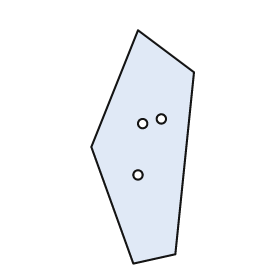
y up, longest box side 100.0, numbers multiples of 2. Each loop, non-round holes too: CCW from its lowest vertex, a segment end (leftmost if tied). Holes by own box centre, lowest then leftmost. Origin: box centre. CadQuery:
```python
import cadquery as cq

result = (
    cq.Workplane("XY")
    .moveTo(-4.0, -50.0)
    .lineTo(14.0, -46.0)
    .lineTo(22.0, 32.0)
    .lineTo(-2.0, 50.0)
    .lineTo(-22.0, 0.0)
    .close()
    .moveTo(-2.0, -12.0)
    .circle(2.0)
    .moveTo(0.0, 10.0)
    .circle(2.0)
    .moveTo(8.0, 12.0)
    .circle(2.0)
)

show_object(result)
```